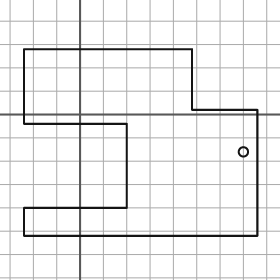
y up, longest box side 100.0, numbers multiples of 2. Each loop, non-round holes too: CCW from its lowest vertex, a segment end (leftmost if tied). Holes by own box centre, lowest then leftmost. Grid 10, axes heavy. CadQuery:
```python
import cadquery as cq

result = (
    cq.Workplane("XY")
    .moveTo(-24.0, -52.0)
    .lineTo(76.0, -52.0)
    .lineTo(76.0, 2.0)
    .lineTo(48.0, 2.0)
    .lineTo(48.0, 28.0)
    .lineTo(-24.0, 28.0)
    .lineTo(-24.0, -4.0)
    .lineTo(20.0, -4.0)
    .lineTo(20.0, -40.0)
    .lineTo(-24.0, -40.0)
    .close()
    .moveTo(70.0, -16.0)
    .circle(2.0)
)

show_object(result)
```